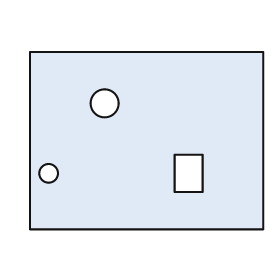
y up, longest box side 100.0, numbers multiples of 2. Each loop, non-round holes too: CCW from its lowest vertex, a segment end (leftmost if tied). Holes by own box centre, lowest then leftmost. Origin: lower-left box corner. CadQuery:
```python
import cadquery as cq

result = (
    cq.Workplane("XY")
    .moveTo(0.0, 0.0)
    .lineTo(100.0, 0.0)
    .lineTo(100.0, 76.0)
    .lineTo(0.0, 76.0)
    .close()
    .moveTo(8.0, 24.0)
    .circle(4.0)
    .moveTo(62.0, 16.0)
    .lineTo(74.0, 16.0)
    .lineTo(74.0, 32.0)
    .lineTo(62.0, 32.0)
    .close()
    .moveTo(32.0, 54.0)
    .circle(6.0)
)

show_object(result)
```